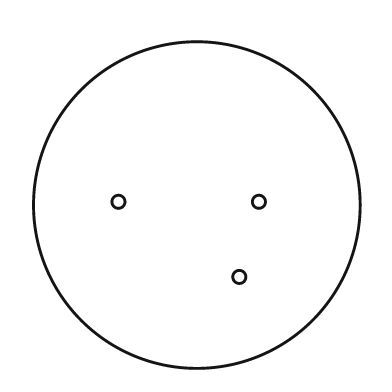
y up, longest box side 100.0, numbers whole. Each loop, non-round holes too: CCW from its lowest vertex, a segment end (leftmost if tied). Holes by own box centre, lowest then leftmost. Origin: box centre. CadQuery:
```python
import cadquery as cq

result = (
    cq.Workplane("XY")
    .moveTo(0.0, 0.0)
    .circle(50.0)
    .moveTo(13.0, -22.0)
    .circle(2.0)
    .moveTo(-24.0, 1.0)
    .circle(2.0)
    .moveTo(19.0, 1.0)
    .circle(2.0)
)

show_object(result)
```